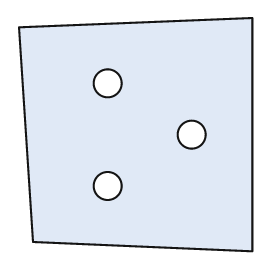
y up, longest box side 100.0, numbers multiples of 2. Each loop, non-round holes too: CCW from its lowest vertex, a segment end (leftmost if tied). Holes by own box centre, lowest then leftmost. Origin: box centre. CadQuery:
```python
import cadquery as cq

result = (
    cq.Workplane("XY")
    .moveTo(50.0, -50.0)
    .lineTo(50.0, 50.0)
    .lineTo(-50.0, 46.0)
    .lineTo(-44.0, -46.0)
    .close()
    .moveTo(-12.0, -22.0)
    .circle(6.0)
    .moveTo(24.0, 0.0)
    .circle(6.0)
    .moveTo(-12.0, 22.0)
    .circle(6.0)
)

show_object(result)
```